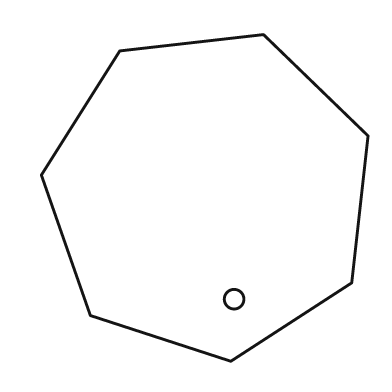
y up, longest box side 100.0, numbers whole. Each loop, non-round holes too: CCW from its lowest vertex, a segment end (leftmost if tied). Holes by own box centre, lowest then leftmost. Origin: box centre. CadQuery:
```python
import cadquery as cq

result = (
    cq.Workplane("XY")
    .moveTo(8.0, -50.0)
    .lineTo(45.0, -26.0)
    .lineTo(50.0, 19.0)
    .lineTo(18.0, 50.0)
    .lineTo(-26.0, 45.0)
    .lineTo(-50.0, 7.0)
    .lineTo(-35.0, -36.0)
    .close()
    .moveTo(9.0, -31.0)
    .circle(3.0)
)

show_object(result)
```